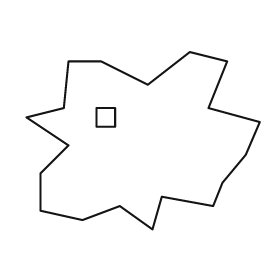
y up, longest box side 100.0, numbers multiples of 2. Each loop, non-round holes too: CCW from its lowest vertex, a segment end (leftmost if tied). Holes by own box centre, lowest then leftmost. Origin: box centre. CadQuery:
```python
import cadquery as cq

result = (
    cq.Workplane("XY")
    .moveTo(4.0, -38.0)
    .lineTo(8.0, -24.0)
    .lineTo(30.0, -28.0)
    .lineTo(34.0, -18.0)
    .lineTo(44.0, -6.0)
    .lineTo(50.0, 8.0)
    .lineTo(28.0, 14.0)
    .lineTo(36.0, 34.0)
    .lineTo(20.0, 38.0)
    .lineTo(2.0, 24.0)
    .lineTo(-18.0, 34.0)
    .lineTo(-32.0, 34.0)
    .lineTo(-34.0, 14.0)
    .lineTo(-50.0, 10.0)
    .lineTo(-32.0, -2.0)
    .lineTo(-44.0, -14.0)
    .lineTo(-44.0, -30.0)
    .lineTo(-26.0, -34.0)
    .lineTo(-10.0, -28.0)
    .close()
    .moveTo(-20.0, 6.0)
    .lineTo(-12.0, 6.0)
    .lineTo(-12.0, 14.0)
    .lineTo(-20.0, 14.0)
    .close()
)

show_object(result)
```